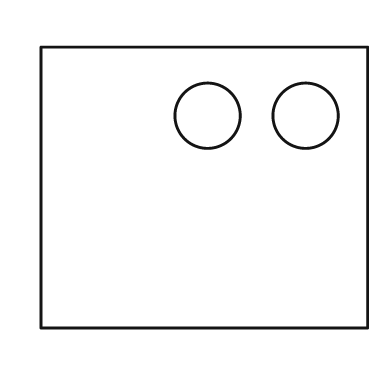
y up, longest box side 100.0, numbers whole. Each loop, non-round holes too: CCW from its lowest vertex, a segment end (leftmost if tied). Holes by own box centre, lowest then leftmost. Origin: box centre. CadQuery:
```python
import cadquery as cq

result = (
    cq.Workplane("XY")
    .moveTo(-50.0, -43.0)
    .lineTo(50.0, -43.0)
    .lineTo(50.0, 43.0)
    .lineTo(-50.0, 43.0)
    .close()
    .moveTo(1.0, 22.0)
    .circle(10.0)
    .moveTo(31.0, 22.0)
    .circle(10.0)
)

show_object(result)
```